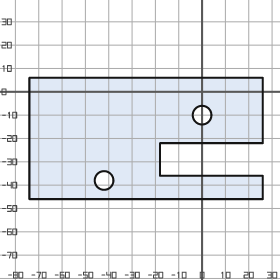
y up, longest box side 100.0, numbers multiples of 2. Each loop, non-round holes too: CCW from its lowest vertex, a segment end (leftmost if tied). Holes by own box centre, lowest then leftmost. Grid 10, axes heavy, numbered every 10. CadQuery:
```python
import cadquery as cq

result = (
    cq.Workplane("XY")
    .moveTo(-74.0, -46.0)
    .lineTo(26.0, -46.0)
    .lineTo(26.0, -36.0)
    .lineTo(-18.0, -36.0)
    .lineTo(-18.0, -22.0)
    .lineTo(26.0, -22.0)
    .lineTo(26.0, 6.0)
    .lineTo(-74.0, 6.0)
    .close()
    .moveTo(-42.0, -38.0)
    .circle(4.0)
    .moveTo(0.0, -10.0)
    .circle(4.0)
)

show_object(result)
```